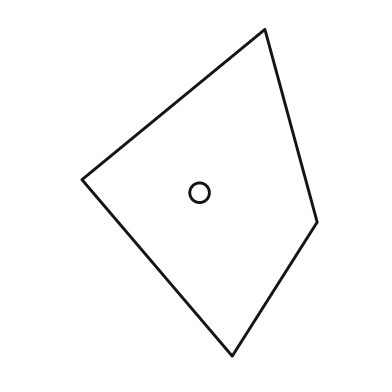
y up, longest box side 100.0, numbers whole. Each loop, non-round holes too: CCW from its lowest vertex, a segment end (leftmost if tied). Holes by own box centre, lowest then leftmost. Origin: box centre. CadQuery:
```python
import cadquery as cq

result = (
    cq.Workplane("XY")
    .moveTo(10.0, -50.0)
    .lineTo(36.0, -9.0)
    .lineTo(20.0, 50.0)
    .lineTo(-36.0, 4.0)
    .close()
    .moveTo(0.0, 0.0)
    .circle(3.0)
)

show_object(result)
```